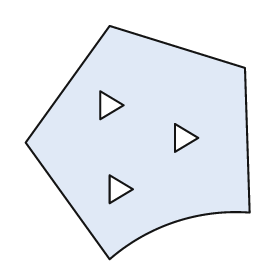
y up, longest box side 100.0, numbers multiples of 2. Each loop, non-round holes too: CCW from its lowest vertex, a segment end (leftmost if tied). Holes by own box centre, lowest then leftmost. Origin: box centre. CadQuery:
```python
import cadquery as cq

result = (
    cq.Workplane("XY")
    .moveTo(-12.0, -50.0)
    .threePointArc((16.0, -34.0), (48.0, -30.0))
    .lineTo(46.0, 32.0)
    .lineTo(-12.0, 50.0)
    .lineTo(-48.0, 0.0)
    .close()
    .moveTo(-12.0, -26.0)
    .lineTo(-2.0, -20.0)
    .lineTo(-12.0, -14.0)
    .close()
    .moveTo(16.0, -4.0)
    .lineTo(26.0, 2.0)
    .lineTo(16.0, 8.0)
    .close()
    .moveTo(-16.0, 10.0)
    .lineTo(-6.0, 16.0)
    .lineTo(-16.0, 22.0)
    .close()
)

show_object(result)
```